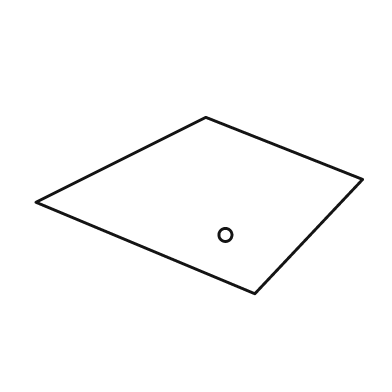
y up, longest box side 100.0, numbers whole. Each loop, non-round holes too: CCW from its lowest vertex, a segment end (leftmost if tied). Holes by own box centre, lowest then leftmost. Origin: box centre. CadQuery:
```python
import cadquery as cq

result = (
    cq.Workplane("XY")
    .moveTo(17.0, -27.0)
    .lineTo(50.0, 8.0)
    .lineTo(2.0, 27.0)
    .lineTo(-50.0, 1.0)
    .close()
    .moveTo(8.0, -9.0)
    .circle(2.0)
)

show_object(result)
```